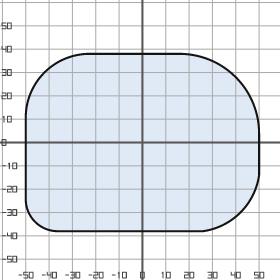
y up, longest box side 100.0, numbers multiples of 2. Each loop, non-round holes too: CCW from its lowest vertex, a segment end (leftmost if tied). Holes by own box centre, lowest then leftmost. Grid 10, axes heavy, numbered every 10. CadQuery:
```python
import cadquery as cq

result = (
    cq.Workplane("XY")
    .moveTo(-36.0, -38.0)
    .lineTo(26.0, -38.0)
    .threePointArc((42.0, -30.0), (50.0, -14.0))
    .lineTo(50.0, 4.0)
    .threePointArc((40.0, 28.0), (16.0, 38.0))
    .lineTo(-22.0, 38.0)
    .threePointArc((-42.0, 30.0), (-50.0, 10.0))
    .lineTo(-50.0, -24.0)
    .threePointArc((-46.0, -34.0), (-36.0, -38.0))
    .close()
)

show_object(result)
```